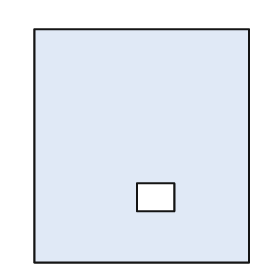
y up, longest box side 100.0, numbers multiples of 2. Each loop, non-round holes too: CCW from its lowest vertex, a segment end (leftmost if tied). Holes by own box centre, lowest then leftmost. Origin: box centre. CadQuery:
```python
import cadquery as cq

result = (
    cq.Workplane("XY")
    .moveTo(-46.0, -50.0)
    .lineTo(46.0, -50.0)
    .lineTo(46.0, 50.0)
    .lineTo(-46.0, 50.0)
    .close()
    .moveTo(-2.0, -28.0)
    .lineTo(14.0, -28.0)
    .lineTo(14.0, -16.0)
    .lineTo(-2.0, -16.0)
    .close()
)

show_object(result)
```